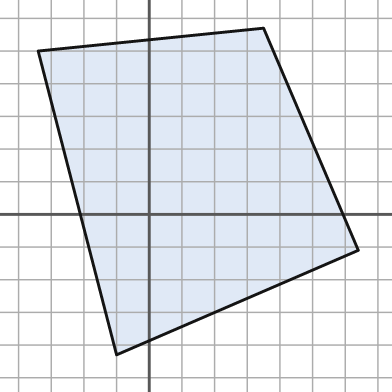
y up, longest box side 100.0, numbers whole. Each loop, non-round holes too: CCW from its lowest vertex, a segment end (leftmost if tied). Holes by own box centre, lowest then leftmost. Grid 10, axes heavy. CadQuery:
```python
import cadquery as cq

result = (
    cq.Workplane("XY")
    .moveTo(-10.0, -43.0)
    .lineTo(64.0, -11.0)
    .lineTo(35.0, 57.0)
    .lineTo(-34.0, 50.0)
    .close()
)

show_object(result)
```